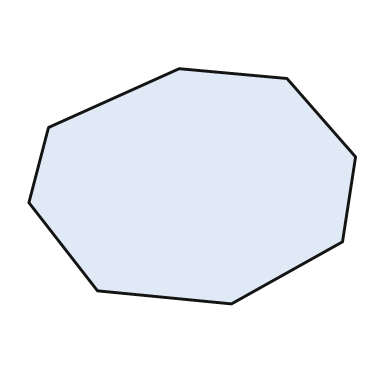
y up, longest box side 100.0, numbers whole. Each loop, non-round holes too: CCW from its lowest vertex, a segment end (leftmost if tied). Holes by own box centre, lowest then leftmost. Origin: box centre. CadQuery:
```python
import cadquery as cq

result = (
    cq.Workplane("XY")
    .moveTo(12.0, -36.0)
    .lineTo(46.0, -17.0)
    .lineTo(50.0, 9.0)
    .lineTo(29.0, 33.0)
    .lineTo(-4.0, 36.0)
    .lineTo(-44.0, 18.0)
    .lineTo(-50.0, -5.0)
    .lineTo(-29.0, -32.0)
    .close()
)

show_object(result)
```